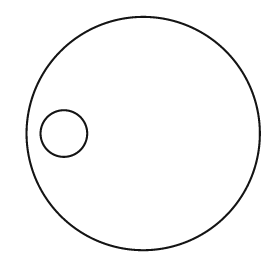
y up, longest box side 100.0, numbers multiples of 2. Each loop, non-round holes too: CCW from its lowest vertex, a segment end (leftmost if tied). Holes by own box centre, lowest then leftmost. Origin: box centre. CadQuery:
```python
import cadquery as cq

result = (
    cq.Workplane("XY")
    .moveTo(0.0, 0.0)
    .circle(50.0)
    .moveTo(-34.0, 0.0)
    .circle(10.0)
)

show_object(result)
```